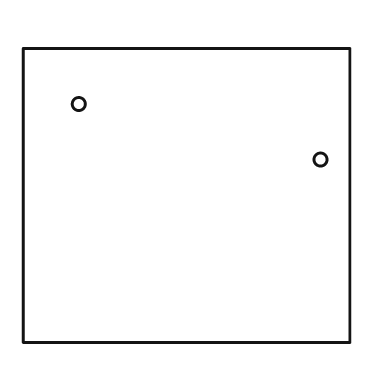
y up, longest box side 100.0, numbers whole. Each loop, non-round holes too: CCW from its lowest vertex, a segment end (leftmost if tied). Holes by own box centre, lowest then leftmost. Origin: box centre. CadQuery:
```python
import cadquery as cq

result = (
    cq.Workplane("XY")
    .moveTo(-50.0, -45.0)
    .lineTo(50.0, -45.0)
    .lineTo(50.0, 45.0)
    .lineTo(-50.0, 45.0)
    .close()
    .moveTo(41.0, 11.0)
    .circle(2.0)
    .moveTo(-33.0, 28.0)
    .circle(2.0)
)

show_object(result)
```